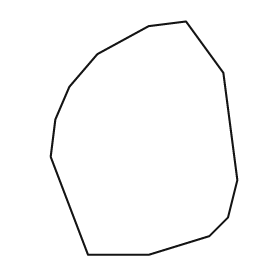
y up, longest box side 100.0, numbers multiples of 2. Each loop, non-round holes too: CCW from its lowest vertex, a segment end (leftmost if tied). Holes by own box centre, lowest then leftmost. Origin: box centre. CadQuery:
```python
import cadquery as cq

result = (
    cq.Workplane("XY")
    .moveTo(-24.0, -50.0)
    .lineTo(2.0, -50.0)
    .lineTo(28.0, -42.0)
    .lineTo(36.0, -34.0)
    .lineTo(40.0, -18.0)
    .lineTo(34.0, 28.0)
    .lineTo(18.0, 50.0)
    .lineTo(2.0, 48.0)
    .lineTo(-20.0, 36.0)
    .lineTo(-32.0, 22.0)
    .lineTo(-38.0, 8.0)
    .lineTo(-40.0, -8.0)
    .close()
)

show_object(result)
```